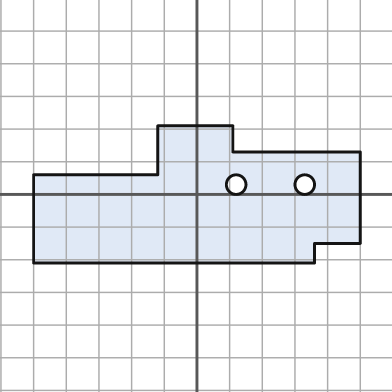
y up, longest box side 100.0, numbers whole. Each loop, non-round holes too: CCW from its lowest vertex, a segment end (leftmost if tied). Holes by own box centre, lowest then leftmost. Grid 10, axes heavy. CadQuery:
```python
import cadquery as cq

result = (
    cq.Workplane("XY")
    .moveTo(-50.0, -21.0)
    .lineTo(36.0, -21.0)
    .lineTo(36.0, -15.0)
    .lineTo(50.0, -15.0)
    .lineTo(50.0, 13.0)
    .lineTo(11.0, 13.0)
    .lineTo(11.0, 21.0)
    .lineTo(-12.0, 21.0)
    .lineTo(-12.0, 6.0)
    .lineTo(-50.0, 6.0)
    .close()
    .moveTo(12.0, 3.0)
    .circle(3.0)
    .moveTo(33.0, 3.0)
    .circle(3.0)
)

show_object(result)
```